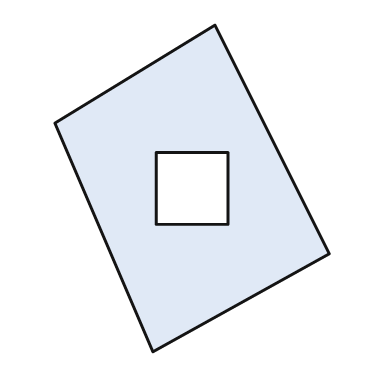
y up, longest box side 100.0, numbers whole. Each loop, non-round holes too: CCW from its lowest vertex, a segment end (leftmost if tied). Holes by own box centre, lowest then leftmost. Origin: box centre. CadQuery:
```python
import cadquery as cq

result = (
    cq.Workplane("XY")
    .moveTo(-12.0, -50.0)
    .lineTo(42.0, -20.0)
    .lineTo(7.0, 50.0)
    .lineTo(-42.0, 20.0)
    .close()
    .moveTo(-11.0, -11.0)
    .lineTo(11.0, -11.0)
    .lineTo(11.0, 11.0)
    .lineTo(-11.0, 11.0)
    .close()
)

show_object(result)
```